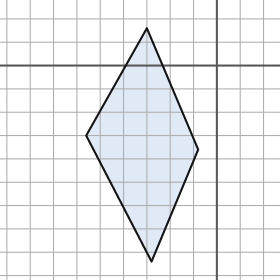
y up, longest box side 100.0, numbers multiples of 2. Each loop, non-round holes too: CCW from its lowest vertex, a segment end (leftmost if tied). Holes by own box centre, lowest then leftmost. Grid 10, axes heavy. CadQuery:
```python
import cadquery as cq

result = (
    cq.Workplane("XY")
    .moveTo(-28.0, -84.0)
    .lineTo(-8.0, -36.0)
    .lineTo(-30.0, 16.0)
    .lineTo(-56.0, -30.0)
    .close()
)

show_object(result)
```